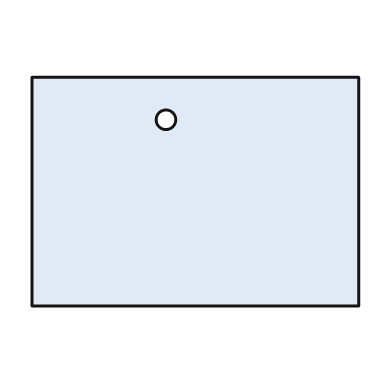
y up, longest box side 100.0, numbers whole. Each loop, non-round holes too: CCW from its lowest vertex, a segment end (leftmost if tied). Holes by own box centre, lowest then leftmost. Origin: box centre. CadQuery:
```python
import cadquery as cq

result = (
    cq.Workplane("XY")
    .moveTo(-50.0, -35.0)
    .lineTo(50.0, -35.0)
    .lineTo(50.0, 35.0)
    .lineTo(-50.0, 35.0)
    .close()
    .moveTo(-9.0, 22.0)
    .circle(3.0)
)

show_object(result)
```